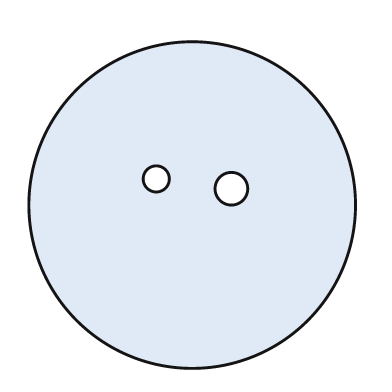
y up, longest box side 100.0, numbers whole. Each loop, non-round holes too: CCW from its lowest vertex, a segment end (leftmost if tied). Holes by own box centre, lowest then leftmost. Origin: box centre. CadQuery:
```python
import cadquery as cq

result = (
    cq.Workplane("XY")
    .moveTo(0.0, 0.0)
    .circle(50.0)
    .moveTo(12.0, 5.0)
    .circle(5.0)
    .moveTo(-11.0, 8.0)
    .circle(4.0)
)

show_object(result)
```